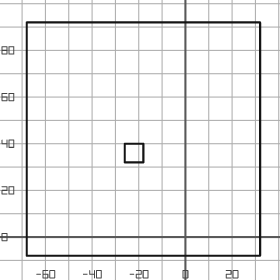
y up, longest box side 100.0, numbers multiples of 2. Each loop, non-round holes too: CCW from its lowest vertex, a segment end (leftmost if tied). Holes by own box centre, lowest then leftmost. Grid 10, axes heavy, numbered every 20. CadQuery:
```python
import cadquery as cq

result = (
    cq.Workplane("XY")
    .moveTo(-68.0, -8.0)
    .lineTo(32.0, -8.0)
    .lineTo(32.0, 92.0)
    .lineTo(-68.0, 92.0)
    .close()
    .moveTo(-26.0, 32.0)
    .lineTo(-18.0, 32.0)
    .lineTo(-18.0, 40.0)
    .lineTo(-26.0, 40.0)
    .close()
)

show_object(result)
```